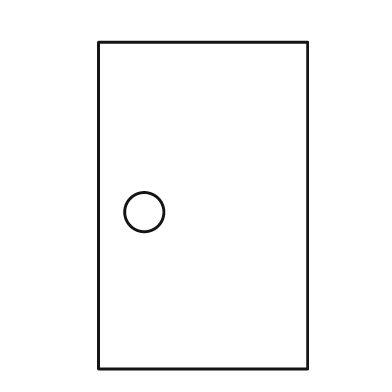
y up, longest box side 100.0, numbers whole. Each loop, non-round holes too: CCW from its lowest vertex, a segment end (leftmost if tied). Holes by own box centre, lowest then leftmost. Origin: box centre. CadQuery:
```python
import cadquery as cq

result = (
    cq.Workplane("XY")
    .moveTo(-32.0, -50.0)
    .lineTo(32.0, -50.0)
    .lineTo(32.0, 50.0)
    .lineTo(-32.0, 50.0)
    .close()
    .moveTo(-18.0, -2.0)
    .circle(6.0)
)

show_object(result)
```